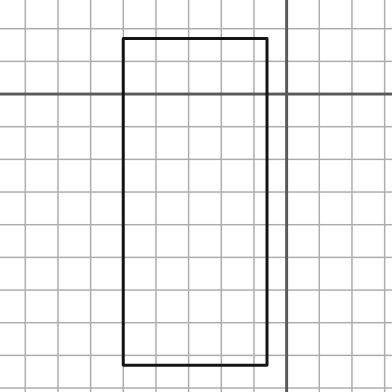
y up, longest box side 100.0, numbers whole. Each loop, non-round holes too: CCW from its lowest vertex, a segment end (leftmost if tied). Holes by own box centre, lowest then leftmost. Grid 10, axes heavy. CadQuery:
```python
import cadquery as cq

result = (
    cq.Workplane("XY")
    .moveTo(-50.0, -83.0)
    .lineTo(-6.0, -83.0)
    .lineTo(-6.0, 17.0)
    .lineTo(-50.0, 17.0)
    .close()
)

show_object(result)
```